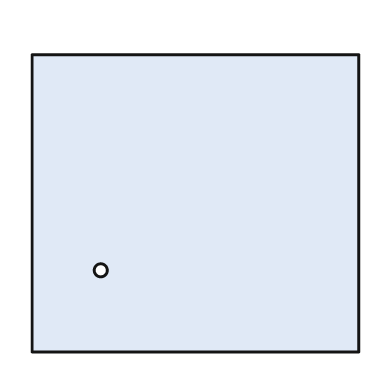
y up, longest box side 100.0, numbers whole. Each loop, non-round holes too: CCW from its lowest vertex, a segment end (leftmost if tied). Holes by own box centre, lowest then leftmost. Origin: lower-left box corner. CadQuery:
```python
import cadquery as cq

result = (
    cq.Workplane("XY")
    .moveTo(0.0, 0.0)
    .lineTo(100.0, 0.0)
    .lineTo(100.0, 91.0)
    .lineTo(0.0, 91.0)
    .close()
    .moveTo(21.0, 25.0)
    .circle(2.0)
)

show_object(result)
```